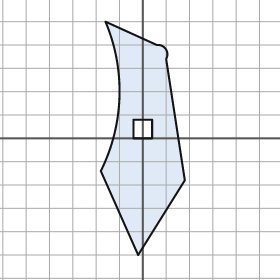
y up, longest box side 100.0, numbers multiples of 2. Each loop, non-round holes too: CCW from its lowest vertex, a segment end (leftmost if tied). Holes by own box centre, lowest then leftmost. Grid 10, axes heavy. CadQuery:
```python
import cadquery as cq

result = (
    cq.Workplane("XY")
    .moveTo(-2.0, -50.0)
    .lineTo(18.0, -18.0)
    .lineTo(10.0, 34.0)
    .threePointArc((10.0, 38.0), (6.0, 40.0))
    .lineTo(-16.0, 50.0)
    .threePointArc((-10.0, 18.0), (-18.0, -14.0))
    .close()
    .moveTo(-4.0, 0.0)
    .lineTo(4.0, 0.0)
    .lineTo(4.0, 8.0)
    .lineTo(-4.0, 8.0)
    .close()
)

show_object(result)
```